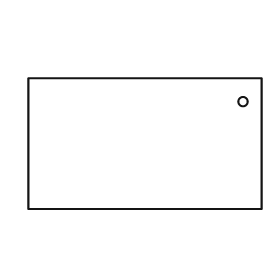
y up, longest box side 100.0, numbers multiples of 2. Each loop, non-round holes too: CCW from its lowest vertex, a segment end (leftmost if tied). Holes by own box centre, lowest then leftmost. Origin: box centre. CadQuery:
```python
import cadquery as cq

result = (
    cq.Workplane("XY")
    .moveTo(-50.0, -28.0)
    .lineTo(50.0, -28.0)
    .lineTo(50.0, 28.0)
    .lineTo(-50.0, 28.0)
    .close()
    .moveTo(42.0, 18.0)
    .circle(2.0)
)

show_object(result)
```